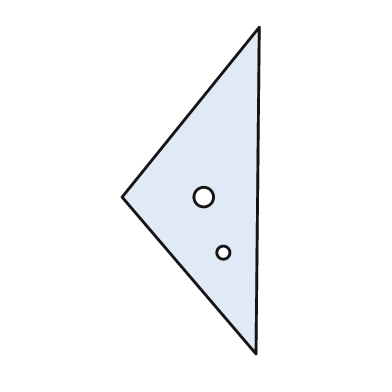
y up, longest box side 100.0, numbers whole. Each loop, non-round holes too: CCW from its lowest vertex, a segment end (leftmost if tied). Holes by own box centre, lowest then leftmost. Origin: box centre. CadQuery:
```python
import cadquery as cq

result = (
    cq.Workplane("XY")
    .moveTo(20.0, -50.0)
    .lineTo(21.0, 50.0)
    .lineTo(-21.0, -2.0)
    .close()
    .moveTo(10.0, -19.0)
    .circle(2.0)
    .moveTo(4.0, -2.0)
    .circle(3.0)
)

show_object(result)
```